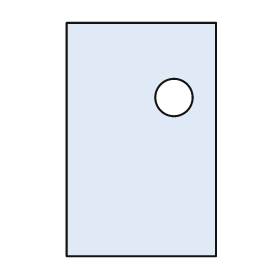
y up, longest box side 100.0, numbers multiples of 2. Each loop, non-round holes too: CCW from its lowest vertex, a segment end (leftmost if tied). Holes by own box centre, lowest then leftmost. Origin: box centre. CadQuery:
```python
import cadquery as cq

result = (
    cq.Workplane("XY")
    .moveTo(-32.0, -50.0)
    .lineTo(32.0, -50.0)
    .lineTo(32.0, 50.0)
    .lineTo(-32.0, 50.0)
    .close()
    .moveTo(14.0, 18.0)
    .circle(8.0)
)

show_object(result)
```